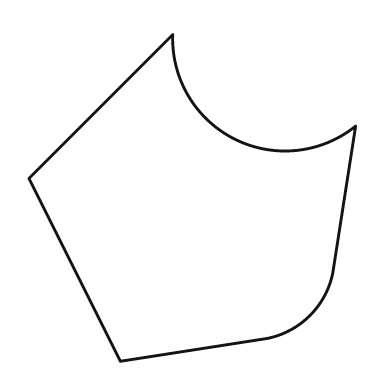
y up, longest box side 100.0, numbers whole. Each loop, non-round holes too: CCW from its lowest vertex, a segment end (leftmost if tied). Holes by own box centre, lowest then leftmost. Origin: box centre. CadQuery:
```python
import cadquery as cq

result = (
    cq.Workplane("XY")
    .moveTo(-22.0, -50.0)
    .lineTo(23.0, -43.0)
    .threePointArc((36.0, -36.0), (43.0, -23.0))
    .lineTo(50.0, 22.0)
    .threePointArc((13.0, 18.0), (-6.0, 50.0))
    .lineTo(-50.0, 6.0)
    .close()
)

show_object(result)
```